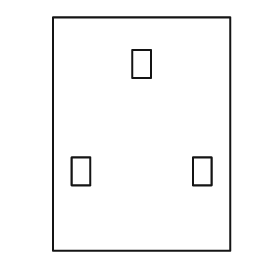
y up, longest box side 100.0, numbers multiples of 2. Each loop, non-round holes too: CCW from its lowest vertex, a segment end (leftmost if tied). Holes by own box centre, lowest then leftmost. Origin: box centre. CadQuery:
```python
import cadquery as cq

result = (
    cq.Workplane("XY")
    .moveTo(-38.0, -50.0)
    .lineTo(38.0, -50.0)
    .lineTo(38.0, 50.0)
    .lineTo(-38.0, 50.0)
    .close()
    .moveTo(-30.0, -22.0)
    .lineTo(-22.0, -22.0)
    .lineTo(-22.0, -10.0)
    .lineTo(-30.0, -10.0)
    .close()
    .moveTo(22.0, -22.0)
    .lineTo(30.0, -22.0)
    .lineTo(30.0, -10.0)
    .lineTo(22.0, -10.0)
    .close()
    .moveTo(-4.0, 24.0)
    .lineTo(4.0, 24.0)
    .lineTo(4.0, 36.0)
    .lineTo(-4.0, 36.0)
    .close()
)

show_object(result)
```